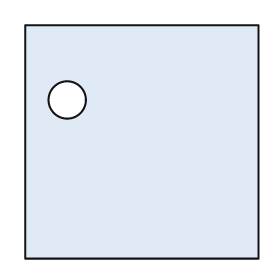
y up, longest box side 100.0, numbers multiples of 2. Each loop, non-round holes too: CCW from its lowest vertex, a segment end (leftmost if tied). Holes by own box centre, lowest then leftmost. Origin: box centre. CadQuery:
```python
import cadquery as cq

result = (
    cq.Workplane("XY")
    .moveTo(-50.0, -50.0)
    .lineTo(50.0, -50.0)
    .lineTo(50.0, 50.0)
    .lineTo(-50.0, 50.0)
    .close()
    .moveTo(-32.0, 18.0)
    .circle(8.0)
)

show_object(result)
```